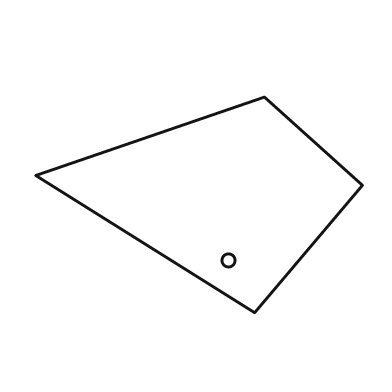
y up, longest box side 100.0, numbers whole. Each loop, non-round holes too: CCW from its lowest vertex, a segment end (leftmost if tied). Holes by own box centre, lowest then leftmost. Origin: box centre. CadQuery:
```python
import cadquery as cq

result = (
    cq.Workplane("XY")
    .moveTo(17.0, -33.0)
    .lineTo(50.0, 6.0)
    .lineTo(20.0, 33.0)
    .lineTo(-50.0, 9.0)
    .close()
    .moveTo(9.0, -17.0)
    .circle(2.0)
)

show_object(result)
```